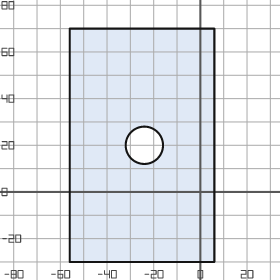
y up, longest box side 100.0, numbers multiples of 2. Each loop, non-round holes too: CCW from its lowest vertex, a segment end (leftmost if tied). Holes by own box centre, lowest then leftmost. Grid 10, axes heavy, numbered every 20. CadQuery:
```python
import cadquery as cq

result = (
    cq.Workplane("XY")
    .moveTo(-56.0, -30.0)
    .lineTo(6.0, -30.0)
    .lineTo(6.0, 70.0)
    .lineTo(-56.0, 70.0)
    .close()
    .moveTo(-24.0, 20.0)
    .circle(8.0)
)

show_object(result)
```